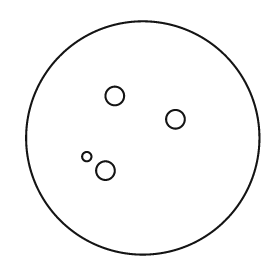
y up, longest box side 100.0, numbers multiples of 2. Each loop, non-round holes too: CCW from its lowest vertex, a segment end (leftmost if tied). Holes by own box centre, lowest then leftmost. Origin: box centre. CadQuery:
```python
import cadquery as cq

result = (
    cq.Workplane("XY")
    .moveTo(0.0, 0.0)
    .circle(50.0)
    .moveTo(-16.0, -14.0)
    .circle(4.0)
    .moveTo(-24.0, -8.0)
    .circle(2.0)
    .moveTo(14.0, 8.0)
    .circle(4.0)
    .moveTo(-12.0, 18.0)
    .circle(4.0)
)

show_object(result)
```